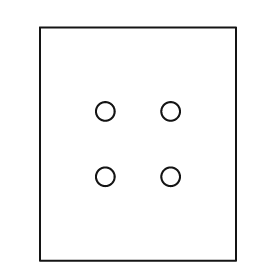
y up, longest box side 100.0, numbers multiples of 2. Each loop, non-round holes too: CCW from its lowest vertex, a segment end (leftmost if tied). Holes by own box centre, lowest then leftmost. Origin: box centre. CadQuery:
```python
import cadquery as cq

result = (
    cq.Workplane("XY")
    .moveTo(-42.0, -50.0)
    .lineTo(42.0, -50.0)
    .lineTo(42.0, 50.0)
    .lineTo(-42.0, 50.0)
    .close()
    .moveTo(-14.0, -14.0)
    .circle(4.0)
    .moveTo(14.0, -14.0)
    .circle(4.0)
    .moveTo(-14.0, 14.0)
    .circle(4.0)
    .moveTo(14.0, 14.0)
    .circle(4.0)
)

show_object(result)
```